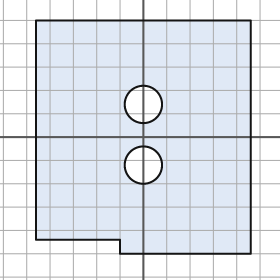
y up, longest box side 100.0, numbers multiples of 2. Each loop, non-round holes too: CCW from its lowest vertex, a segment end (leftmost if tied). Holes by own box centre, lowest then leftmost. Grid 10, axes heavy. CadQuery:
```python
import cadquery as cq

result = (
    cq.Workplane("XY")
    .moveTo(-10.0, -50.0)
    .lineTo(46.0, -50.0)
    .lineTo(46.0, 50.0)
    .lineTo(-46.0, 50.0)
    .lineTo(-46.0, -44.0)
    .lineTo(-10.0, -44.0)
    .close()
    .moveTo(0.0, -12.0)
    .circle(8.0)
    .moveTo(0.0, 14.0)
    .circle(8.0)
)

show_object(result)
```